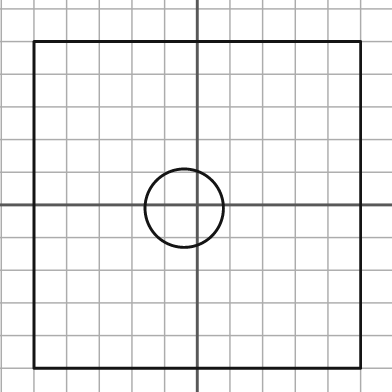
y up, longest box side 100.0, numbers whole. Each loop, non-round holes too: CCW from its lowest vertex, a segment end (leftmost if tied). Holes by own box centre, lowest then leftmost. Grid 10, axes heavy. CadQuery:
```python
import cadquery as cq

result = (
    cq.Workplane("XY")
    .moveTo(-50.0, -50.0)
    .lineTo(50.0, -50.0)
    .lineTo(50.0, 50.0)
    .lineTo(-50.0, 50.0)
    .close()
    .moveTo(-4.0, -1.0)
    .circle(12.0)
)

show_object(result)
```